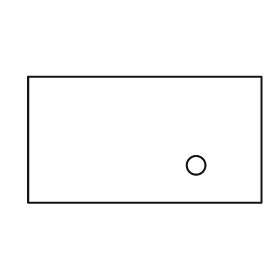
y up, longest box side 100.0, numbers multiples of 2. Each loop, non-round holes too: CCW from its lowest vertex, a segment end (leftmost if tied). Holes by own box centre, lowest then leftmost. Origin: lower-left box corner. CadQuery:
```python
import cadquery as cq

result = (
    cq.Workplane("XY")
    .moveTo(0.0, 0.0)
    .lineTo(100.0, 0.0)
    .lineTo(100.0, 54.0)
    .lineTo(0.0, 54.0)
    .close()
    .moveTo(72.0, 16.0)
    .circle(4.0)
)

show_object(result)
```